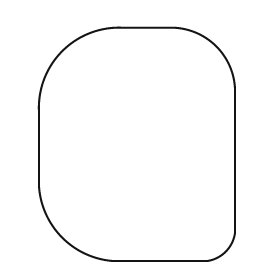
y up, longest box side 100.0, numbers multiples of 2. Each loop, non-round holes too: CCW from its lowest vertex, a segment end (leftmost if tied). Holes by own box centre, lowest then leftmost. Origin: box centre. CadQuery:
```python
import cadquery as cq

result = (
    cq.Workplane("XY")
    .moveTo(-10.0, -50.0)
    .lineTo(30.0, -50.0)
    .threePointArc((38.0, -46.0), (42.0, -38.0))
    .lineTo(42.0, 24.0)
    .threePointArc((34.0, 42.0), (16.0, 50.0))
    .lineTo(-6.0, 50.0)
    .threePointArc((-32.0, 40.0), (-42.0, 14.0))
    .lineTo(-42.0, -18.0)
    .threePointArc((-32.0, -40.0), (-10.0, -50.0))
    .close()
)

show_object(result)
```